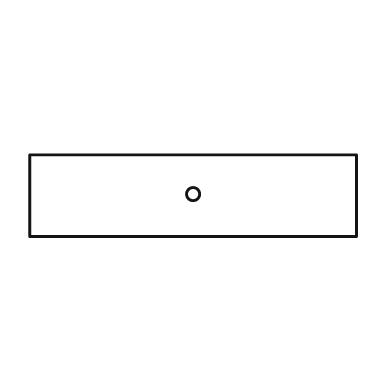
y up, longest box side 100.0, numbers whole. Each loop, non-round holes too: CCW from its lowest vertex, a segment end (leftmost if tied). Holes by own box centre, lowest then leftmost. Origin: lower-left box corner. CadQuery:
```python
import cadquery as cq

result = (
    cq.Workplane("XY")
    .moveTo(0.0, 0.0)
    .lineTo(100.0, 0.0)
    .lineTo(100.0, 25.0)
    .lineTo(0.0, 25.0)
    .close()
    .moveTo(50.0, 13.0)
    .circle(2.0)
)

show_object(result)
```